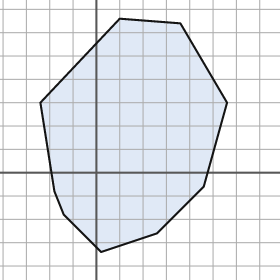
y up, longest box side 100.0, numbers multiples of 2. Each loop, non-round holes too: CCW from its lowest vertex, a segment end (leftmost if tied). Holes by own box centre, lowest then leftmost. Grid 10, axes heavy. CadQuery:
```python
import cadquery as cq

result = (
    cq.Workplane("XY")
    .moveTo(2.0, -34.0)
    .lineTo(26.0, -26.0)
    .lineTo(46.0, -6.0)
    .lineTo(56.0, 30.0)
    .lineTo(36.0, 64.0)
    .lineTo(10.0, 66.0)
    .lineTo(-24.0, 30.0)
    .lineTo(-18.0, -8.0)
    .lineTo(-14.0, -18.0)
    .close()
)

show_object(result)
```